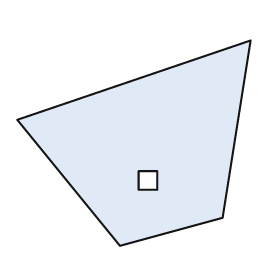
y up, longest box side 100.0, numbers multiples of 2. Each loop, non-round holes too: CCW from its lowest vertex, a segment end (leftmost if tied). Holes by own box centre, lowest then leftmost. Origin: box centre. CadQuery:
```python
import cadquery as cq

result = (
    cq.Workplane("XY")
    .moveTo(-6.0, -44.0)
    .lineTo(38.0, -32.0)
    .lineTo(50.0, 44.0)
    .lineTo(-50.0, 10.0)
    .close()
    .moveTo(2.0, -20.0)
    .lineTo(10.0, -20.0)
    .lineTo(10.0, -12.0)
    .lineTo(2.0, -12.0)
    .close()
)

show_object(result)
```